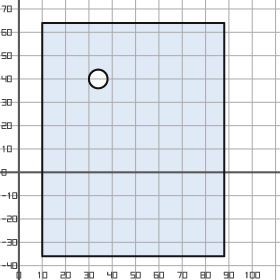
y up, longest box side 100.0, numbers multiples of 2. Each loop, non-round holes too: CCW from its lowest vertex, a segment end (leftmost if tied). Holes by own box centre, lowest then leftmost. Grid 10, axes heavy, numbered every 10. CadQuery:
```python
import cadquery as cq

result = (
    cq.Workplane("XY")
    .moveTo(10.0, -36.0)
    .lineTo(88.0, -36.0)
    .lineTo(88.0, 64.0)
    .lineTo(10.0, 64.0)
    .close()
    .moveTo(34.0, 40.0)
    .circle(4.0)
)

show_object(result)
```